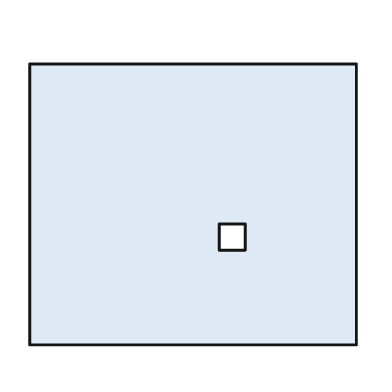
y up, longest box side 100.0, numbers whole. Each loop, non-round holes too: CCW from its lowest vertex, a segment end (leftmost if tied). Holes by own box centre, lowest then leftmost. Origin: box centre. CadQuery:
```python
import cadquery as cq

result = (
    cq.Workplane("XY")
    .moveTo(-50.0, -43.0)
    .lineTo(50.0, -43.0)
    .lineTo(50.0, 43.0)
    .lineTo(-50.0, 43.0)
    .close()
    .moveTo(8.0, -14.0)
    .lineTo(16.0, -14.0)
    .lineTo(16.0, -6.0)
    .lineTo(8.0, -6.0)
    .close()
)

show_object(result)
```